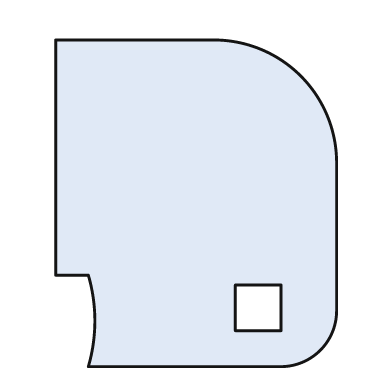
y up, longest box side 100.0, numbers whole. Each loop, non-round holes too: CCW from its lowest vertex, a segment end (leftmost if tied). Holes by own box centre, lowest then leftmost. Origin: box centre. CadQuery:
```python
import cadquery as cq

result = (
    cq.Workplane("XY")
    .moveTo(-33.0, -50.0)
    .lineTo(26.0, -50.0)
    .threePointArc((38.0, -45.0), (43.0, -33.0))
    .lineTo(43.0, 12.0)
    .threePointArc((32.0, 39.0), (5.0, 50.0))
    .lineTo(-43.0, 50.0)
    .lineTo(-43.0, -22.0)
    .lineTo(-33.0, -22.0)
    .threePointArc((-31.0, -36.0), (-33.0, -50.0))
    .close()
    .moveTo(12.0, -39.0)
    .lineTo(26.0, -39.0)
    .lineTo(26.0, -25.0)
    .lineTo(12.0, -25.0)
    .close()
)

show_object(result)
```